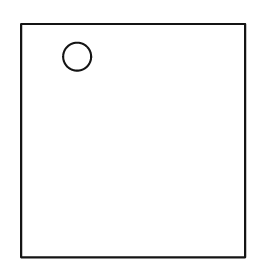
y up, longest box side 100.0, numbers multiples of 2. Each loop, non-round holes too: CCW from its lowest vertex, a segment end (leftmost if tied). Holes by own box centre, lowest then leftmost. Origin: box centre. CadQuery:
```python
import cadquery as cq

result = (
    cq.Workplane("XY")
    .moveTo(-48.0, -50.0)
    .lineTo(48.0, -50.0)
    .lineTo(48.0, 50.0)
    .lineTo(-48.0, 50.0)
    .close()
    .moveTo(-24.0, 36.0)
    .circle(6.0)
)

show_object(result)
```